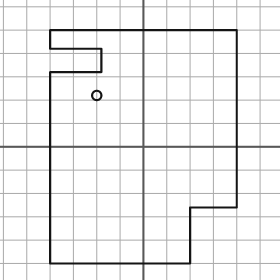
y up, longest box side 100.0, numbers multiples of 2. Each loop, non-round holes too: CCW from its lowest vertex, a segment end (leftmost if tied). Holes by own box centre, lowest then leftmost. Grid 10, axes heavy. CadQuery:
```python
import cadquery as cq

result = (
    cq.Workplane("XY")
    .moveTo(-40.0, -50.0)
    .lineTo(20.0, -50.0)
    .lineTo(20.0, -26.0)
    .lineTo(40.0, -26.0)
    .lineTo(40.0, 50.0)
    .lineTo(-40.0, 50.0)
    .lineTo(-40.0, 42.0)
    .lineTo(-18.0, 42.0)
    .lineTo(-18.0, 32.0)
    .lineTo(-40.0, 32.0)
    .close()
    .moveTo(-20.0, 22.0)
    .circle(2.0)
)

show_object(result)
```